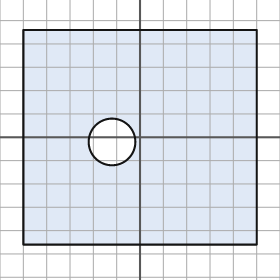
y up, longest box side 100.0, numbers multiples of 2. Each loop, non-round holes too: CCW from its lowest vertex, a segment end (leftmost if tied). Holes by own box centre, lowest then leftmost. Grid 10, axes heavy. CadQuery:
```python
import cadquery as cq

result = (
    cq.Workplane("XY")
    .moveTo(-50.0, -46.0)
    .lineTo(50.0, -46.0)
    .lineTo(50.0, 46.0)
    .lineTo(-50.0, 46.0)
    .close()
    .moveTo(-12.0, -2.0)
    .circle(10.0)
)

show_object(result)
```